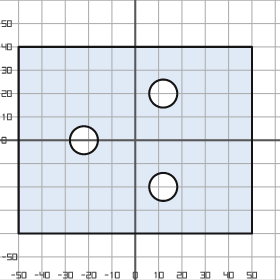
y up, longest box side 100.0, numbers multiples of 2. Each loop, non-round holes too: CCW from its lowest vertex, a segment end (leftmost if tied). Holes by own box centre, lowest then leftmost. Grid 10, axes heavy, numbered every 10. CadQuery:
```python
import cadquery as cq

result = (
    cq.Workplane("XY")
    .moveTo(-50.0, -40.0)
    .lineTo(50.0, -40.0)
    .lineTo(50.0, 40.0)
    .lineTo(-50.0, 40.0)
    .close()
    .moveTo(12.0, -20.0)
    .circle(6.0)
    .moveTo(-22.0, 0.0)
    .circle(6.0)
    .moveTo(12.0, 20.0)
    .circle(6.0)
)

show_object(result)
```